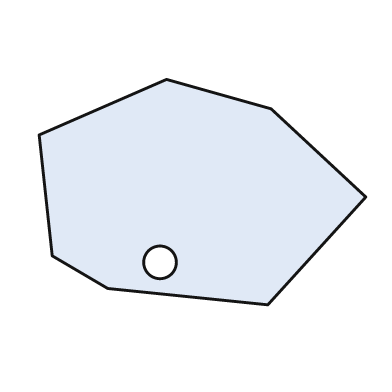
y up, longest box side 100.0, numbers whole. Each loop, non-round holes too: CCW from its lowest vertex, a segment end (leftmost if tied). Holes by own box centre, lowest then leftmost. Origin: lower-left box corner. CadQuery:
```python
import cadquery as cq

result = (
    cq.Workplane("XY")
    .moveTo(70.0, 0.0)
    .lineTo(100.0, 33.0)
    .lineTo(71.0, 60.0)
    .lineTo(39.0, 69.0)
    .lineTo(0.0, 52.0)
    .lineTo(4.0, 15.0)
    .lineTo(21.0, 5.0)
    .close()
    .moveTo(37.0, 13.0)
    .circle(5.0)
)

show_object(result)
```